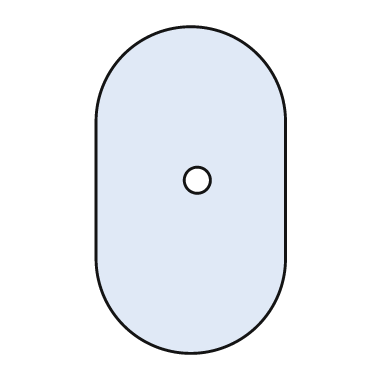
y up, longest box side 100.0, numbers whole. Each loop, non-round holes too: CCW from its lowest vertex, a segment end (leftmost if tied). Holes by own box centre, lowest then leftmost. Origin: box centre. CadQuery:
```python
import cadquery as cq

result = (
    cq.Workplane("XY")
    .moveTo(-29.0, -21.0)
    .threePointArc((0.0, -50.0), (29.0, -21.0))
    .lineTo(29.0, 21.0)
    .threePointArc((0.0, 50.0), (-29.0, 21.0))
    .close()
    .moveTo(2.0, 3.0)
    .circle(4.0)
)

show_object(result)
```